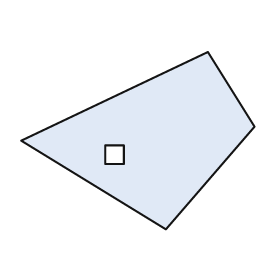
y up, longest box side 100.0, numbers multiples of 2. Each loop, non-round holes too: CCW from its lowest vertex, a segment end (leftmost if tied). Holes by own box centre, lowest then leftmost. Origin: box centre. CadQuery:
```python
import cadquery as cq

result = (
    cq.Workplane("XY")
    .moveTo(12.0, -38.0)
    .lineTo(50.0, 6.0)
    .lineTo(30.0, 38.0)
    .lineTo(-50.0, 0.0)
    .close()
    .moveTo(-14.0, -10.0)
    .lineTo(-6.0, -10.0)
    .lineTo(-6.0, -2.0)
    .lineTo(-14.0, -2.0)
    .close()
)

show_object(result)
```